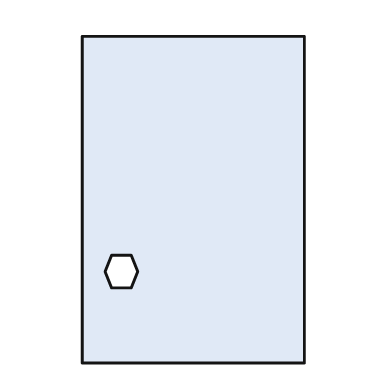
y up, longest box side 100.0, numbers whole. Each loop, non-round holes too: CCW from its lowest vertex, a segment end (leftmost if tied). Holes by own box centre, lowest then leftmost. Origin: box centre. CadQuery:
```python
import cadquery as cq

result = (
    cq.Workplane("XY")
    .moveTo(-34.0, -50.0)
    .lineTo(34.0, -50.0)
    .lineTo(34.0, 50.0)
    .lineTo(-34.0, 50.0)
    .close()
    .moveTo(-25.0, -27.0)
    .lineTo(-19.0, -27.0)
    .lineTo(-17.0, -22.0)
    .lineTo(-19.0, -17.0)
    .lineTo(-25.0, -17.0)
    .lineTo(-27.0, -22.0)
    .close()
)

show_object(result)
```